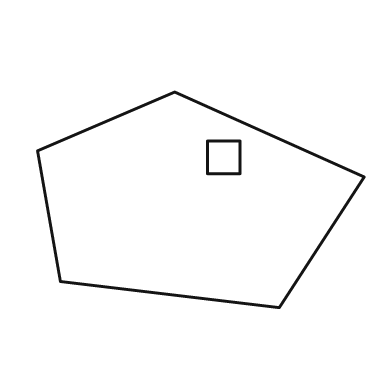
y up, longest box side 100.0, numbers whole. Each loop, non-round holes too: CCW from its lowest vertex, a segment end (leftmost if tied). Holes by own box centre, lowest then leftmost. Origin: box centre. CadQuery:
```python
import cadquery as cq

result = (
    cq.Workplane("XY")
    .moveTo(24.0, -33.0)
    .lineTo(50.0, 7.0)
    .lineTo(-8.0, 33.0)
    .lineTo(-50.0, 15.0)
    .lineTo(-43.0, -25.0)
    .close()
    .moveTo(2.0, 8.0)
    .lineTo(12.0, 8.0)
    .lineTo(12.0, 18.0)
    .lineTo(2.0, 18.0)
    .close()
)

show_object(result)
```